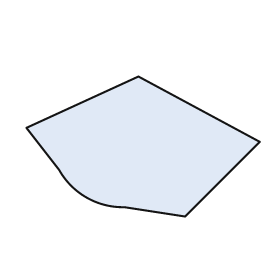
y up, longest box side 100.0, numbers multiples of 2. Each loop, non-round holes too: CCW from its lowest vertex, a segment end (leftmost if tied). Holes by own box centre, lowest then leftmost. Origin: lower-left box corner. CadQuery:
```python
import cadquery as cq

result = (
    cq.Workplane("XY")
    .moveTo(68.0, 0.0)
    .lineTo(100.0, 32.0)
    .lineTo(48.0, 60.0)
    .lineTo(0.0, 38.0)
    .lineTo(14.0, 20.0)
    .threePointArc((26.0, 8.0), (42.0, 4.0))
    .close()
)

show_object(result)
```